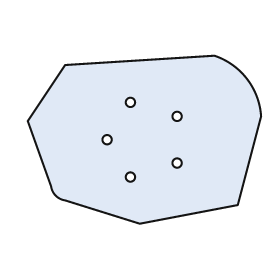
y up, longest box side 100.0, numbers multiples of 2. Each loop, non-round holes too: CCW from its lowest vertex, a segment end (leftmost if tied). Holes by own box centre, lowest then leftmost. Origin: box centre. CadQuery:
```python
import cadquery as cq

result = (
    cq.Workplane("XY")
    .moveTo(-2.0, -36.0)
    .lineTo(40.0, -28.0)
    .lineTo(50.0, 10.0)
    .threePointArc((44.0, 26.0), (30.0, 36.0))
    .lineTo(-34.0, 32.0)
    .lineTo(-50.0, 8.0)
    .lineTo(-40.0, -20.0)
    .threePointArc((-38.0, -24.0), (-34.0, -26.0))
    .close()
    .moveTo(-6.0, -16.0)
    .circle(2.0)
    .moveTo(14.0, -10.0)
    .circle(2.0)
    .moveTo(-16.0, 0.0)
    .circle(2.0)
    .moveTo(14.0, 10.0)
    .circle(2.0)
    .moveTo(-6.0, 16.0)
    .circle(2.0)
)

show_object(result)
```